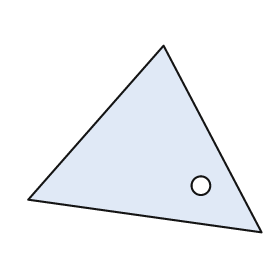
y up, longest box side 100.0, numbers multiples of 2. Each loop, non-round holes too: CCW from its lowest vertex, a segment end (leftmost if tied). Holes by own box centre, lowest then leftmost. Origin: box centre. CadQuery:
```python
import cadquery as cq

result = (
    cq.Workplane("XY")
    .moveTo(50.0, -40.0)
    .lineTo(8.0, 40.0)
    .lineTo(-50.0, -26.0)
    .close()
    .moveTo(24.0, -20.0)
    .circle(4.0)
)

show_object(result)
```